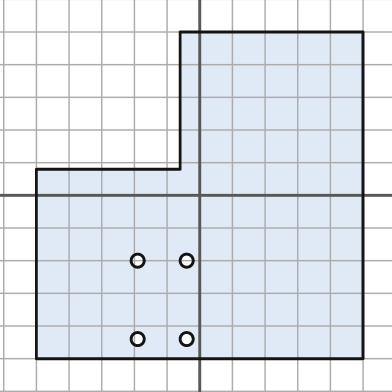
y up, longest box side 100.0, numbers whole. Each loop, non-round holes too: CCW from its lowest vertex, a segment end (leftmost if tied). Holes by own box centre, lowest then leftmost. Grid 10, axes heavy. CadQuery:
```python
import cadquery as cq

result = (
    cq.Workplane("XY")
    .moveTo(-50.0, -50.0)
    .lineTo(50.0, -50.0)
    .lineTo(50.0, 50.0)
    .lineTo(-6.0, 50.0)
    .lineTo(-6.0, 8.0)
    .lineTo(-50.0, 8.0)
    .close()
    .moveTo(-19.0, -44.0)
    .circle(2.0)
    .moveTo(-4.0, -44.0)
    .circle(2.0)
    .moveTo(-19.0, -20.0)
    .circle(2.0)
    .moveTo(-4.0, -20.0)
    .circle(2.0)
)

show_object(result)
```